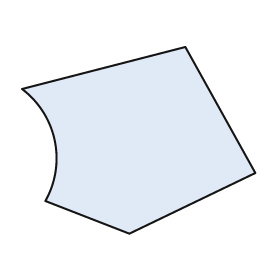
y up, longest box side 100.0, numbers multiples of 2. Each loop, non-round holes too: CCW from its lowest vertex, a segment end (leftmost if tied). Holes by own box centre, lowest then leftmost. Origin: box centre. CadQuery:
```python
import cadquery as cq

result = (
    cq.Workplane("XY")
    .moveTo(-4.0, -40.0)
    .lineTo(50.0, -14.0)
    .lineTo(20.0, 40.0)
    .lineTo(-50.0, 22.0)
    .threePointArc((-36.0, 0.0), (-40.0, -26.0))
    .close()
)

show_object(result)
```